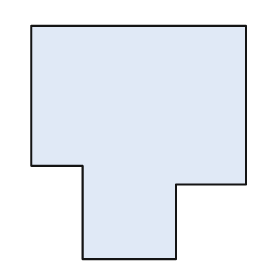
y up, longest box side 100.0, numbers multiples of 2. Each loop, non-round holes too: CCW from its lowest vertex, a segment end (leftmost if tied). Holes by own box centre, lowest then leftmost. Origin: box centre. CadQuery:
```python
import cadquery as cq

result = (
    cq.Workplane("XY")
    .moveTo(-24.0, -50.0)
    .lineTo(16.0, -50.0)
    .lineTo(16.0, -18.0)
    .lineTo(46.0, -18.0)
    .lineTo(46.0, 50.0)
    .lineTo(-46.0, 50.0)
    .lineTo(-46.0, -10.0)
    .lineTo(-24.0, -10.0)
    .close()
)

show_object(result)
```